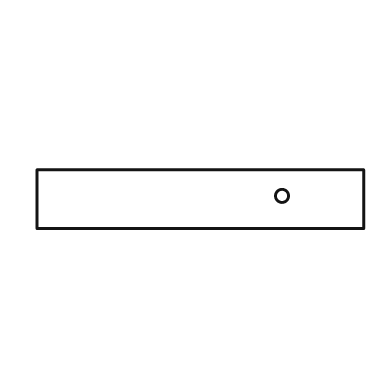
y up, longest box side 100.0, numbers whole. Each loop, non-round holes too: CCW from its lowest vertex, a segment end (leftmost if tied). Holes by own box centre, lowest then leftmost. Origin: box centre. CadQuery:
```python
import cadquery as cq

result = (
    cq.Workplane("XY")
    .moveTo(-50.0, -9.0)
    .lineTo(50.0, -9.0)
    .lineTo(50.0, 9.0)
    .lineTo(-50.0, 9.0)
    .close()
    .moveTo(25.0, 1.0)
    .circle(2.0)
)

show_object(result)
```